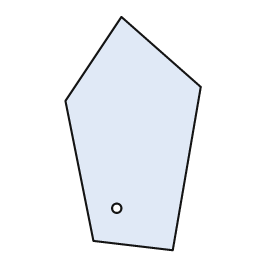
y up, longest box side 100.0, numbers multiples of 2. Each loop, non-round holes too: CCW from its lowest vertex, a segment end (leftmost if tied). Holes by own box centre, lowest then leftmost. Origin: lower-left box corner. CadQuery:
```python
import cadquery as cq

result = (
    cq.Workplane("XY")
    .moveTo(46.0, 0.0)
    .lineTo(58.0, 70.0)
    .lineTo(24.0, 100.0)
    .lineTo(0.0, 64.0)
    .lineTo(12.0, 4.0)
    .close()
    .moveTo(22.0, 18.0)
    .circle(2.0)
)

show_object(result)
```